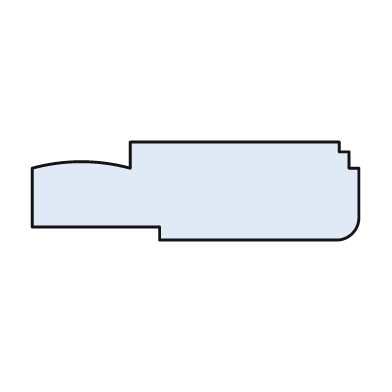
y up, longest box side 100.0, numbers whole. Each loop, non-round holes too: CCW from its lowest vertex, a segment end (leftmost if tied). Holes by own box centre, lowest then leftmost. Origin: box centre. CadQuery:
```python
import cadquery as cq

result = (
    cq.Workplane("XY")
    .moveTo(-11.0, -15.0)
    .lineTo(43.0, -15.0)
    .threePointArc((48.0, -13.0), (50.0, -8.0))
    .lineTo(50.0, 7.0)
    .lineTo(47.0, 7.0)
    .lineTo(47.0, 12.0)
    .lineTo(44.0, 12.0)
    .lineTo(44.0, 15.0)
    .lineTo(-20.0, 15.0)
    .lineTo(-20.0, 7.0)
    .threePointArc((-35.0, 9.0), (-50.0, 7.0))
    .lineTo(-50.0, -11.0)
    .lineTo(-11.0, -11.0)
    .close()
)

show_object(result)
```